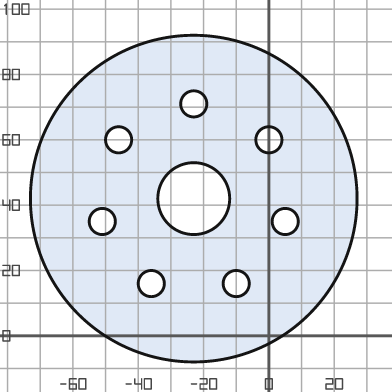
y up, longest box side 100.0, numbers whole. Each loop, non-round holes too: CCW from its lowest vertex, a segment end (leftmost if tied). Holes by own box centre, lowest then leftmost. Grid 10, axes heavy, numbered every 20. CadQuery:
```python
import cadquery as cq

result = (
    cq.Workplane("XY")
    .moveTo(-23.0, 42.0)
    .circle(50.0)
    .moveTo(-36.0, 16.0)
    .circle(4.0)
    .moveTo(-10.0, 16.0)
    .circle(4.0)
    .moveTo(-51.0, 35.0)
    .circle(4.0)
    .moveTo(5.0, 35.0)
    .circle(4.0)
    .moveTo(-23.0, 42.0)
    .circle(11.0)
    .moveTo(-46.0, 60.0)
    .circle(4.0)
    .moveTo(0.0, 60.0)
    .circle(4.0)
    .moveTo(-23.0, 71.0)
    .circle(4.0)
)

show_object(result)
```